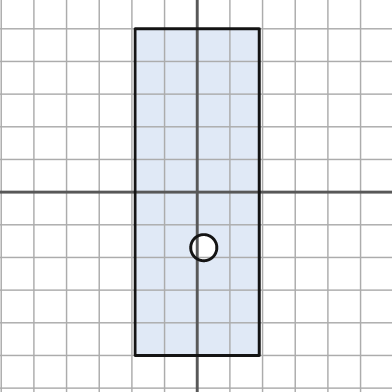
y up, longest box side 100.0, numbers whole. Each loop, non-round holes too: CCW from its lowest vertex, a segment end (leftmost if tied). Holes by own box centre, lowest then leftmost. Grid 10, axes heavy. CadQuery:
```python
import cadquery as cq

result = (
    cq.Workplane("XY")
    .moveTo(-19.0, -50.0)
    .lineTo(19.0, -50.0)
    .lineTo(19.0, 50.0)
    .lineTo(-19.0, 50.0)
    .close()
    .moveTo(2.0, -17.0)
    .circle(4.0)
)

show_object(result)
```